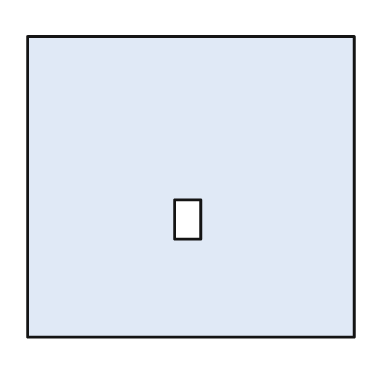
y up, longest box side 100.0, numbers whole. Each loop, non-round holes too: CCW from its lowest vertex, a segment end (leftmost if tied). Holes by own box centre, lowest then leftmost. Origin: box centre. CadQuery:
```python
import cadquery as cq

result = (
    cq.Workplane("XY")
    .moveTo(-50.0, -46.0)
    .lineTo(50.0, -46.0)
    .lineTo(50.0, 46.0)
    .lineTo(-50.0, 46.0)
    .close()
    .moveTo(-5.0, -16.0)
    .lineTo(3.0, -16.0)
    .lineTo(3.0, -4.0)
    .lineTo(-5.0, -4.0)
    .close()
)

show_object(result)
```